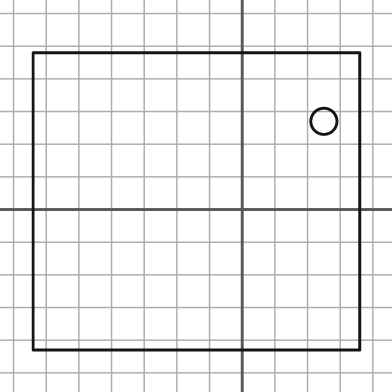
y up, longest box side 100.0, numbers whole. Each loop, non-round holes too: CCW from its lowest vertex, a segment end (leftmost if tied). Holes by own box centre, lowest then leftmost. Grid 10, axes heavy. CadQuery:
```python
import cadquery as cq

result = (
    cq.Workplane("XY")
    .moveTo(-64.0, -43.0)
    .lineTo(36.0, -43.0)
    .lineTo(36.0, 48.0)
    .lineTo(-64.0, 48.0)
    .close()
    .moveTo(25.0, 27.0)
    .circle(4.0)
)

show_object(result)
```